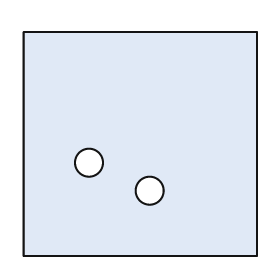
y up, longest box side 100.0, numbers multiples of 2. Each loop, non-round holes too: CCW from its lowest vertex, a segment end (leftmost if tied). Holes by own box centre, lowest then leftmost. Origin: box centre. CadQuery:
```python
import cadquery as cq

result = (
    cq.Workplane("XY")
    .moveTo(-50.0, -48.0)
    .lineTo(50.0, -48.0)
    .lineTo(50.0, 48.0)
    .lineTo(-50.0, 48.0)
    .close()
    .moveTo(4.0, -20.0)
    .circle(6.0)
    .moveTo(-22.0, -8.0)
    .circle(6.0)
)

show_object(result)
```